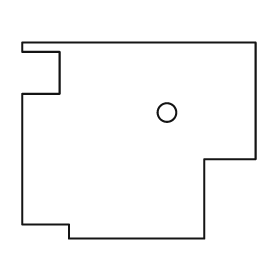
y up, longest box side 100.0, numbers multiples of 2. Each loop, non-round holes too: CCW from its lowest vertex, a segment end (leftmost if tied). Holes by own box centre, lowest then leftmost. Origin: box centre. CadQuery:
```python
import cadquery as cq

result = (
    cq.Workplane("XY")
    .moveTo(-30.0, -42.0)
    .lineTo(28.0, -42.0)
    .lineTo(28.0, -8.0)
    .lineTo(50.0, -8.0)
    .lineTo(50.0, 42.0)
    .lineTo(-50.0, 42.0)
    .lineTo(-50.0, 38.0)
    .lineTo(-34.0, 38.0)
    .lineTo(-34.0, 20.0)
    .lineTo(-50.0, 20.0)
    .lineTo(-50.0, -36.0)
    .lineTo(-30.0, -36.0)
    .close()
    .moveTo(12.0, 12.0)
    .circle(4.0)
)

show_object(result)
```